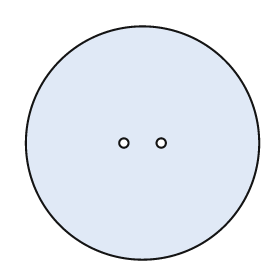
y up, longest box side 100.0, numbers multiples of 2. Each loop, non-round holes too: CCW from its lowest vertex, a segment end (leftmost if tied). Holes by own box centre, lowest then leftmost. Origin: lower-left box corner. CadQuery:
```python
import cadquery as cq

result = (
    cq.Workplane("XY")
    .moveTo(50.0, 50.0)
    .circle(50.0)
    .moveTo(42.0, 50.0)
    .circle(2.0)
    .moveTo(58.0, 50.0)
    .circle(2.0)
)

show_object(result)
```